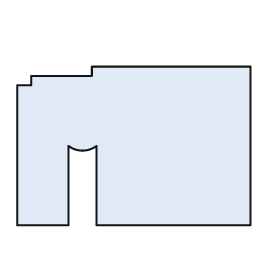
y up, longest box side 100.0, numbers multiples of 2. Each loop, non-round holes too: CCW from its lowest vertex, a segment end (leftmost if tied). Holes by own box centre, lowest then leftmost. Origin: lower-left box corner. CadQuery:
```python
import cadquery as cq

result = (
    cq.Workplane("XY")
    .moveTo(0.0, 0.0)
    .lineTo(22.0, 0.0)
    .lineTo(22.0, 34.0)
    .threePointArc((28.0, 32.0), (34.0, 34.0))
    .lineTo(34.0, 0.0)
    .lineTo(100.0, 0.0)
    .lineTo(100.0, 68.0)
    .lineTo(32.0, 68.0)
    .lineTo(32.0, 64.0)
    .lineTo(6.0, 64.0)
    .lineTo(6.0, 60.0)
    .lineTo(0.0, 60.0)
    .close()
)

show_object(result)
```